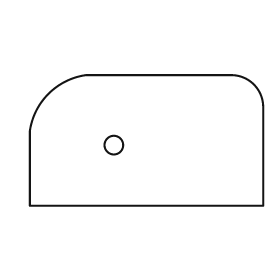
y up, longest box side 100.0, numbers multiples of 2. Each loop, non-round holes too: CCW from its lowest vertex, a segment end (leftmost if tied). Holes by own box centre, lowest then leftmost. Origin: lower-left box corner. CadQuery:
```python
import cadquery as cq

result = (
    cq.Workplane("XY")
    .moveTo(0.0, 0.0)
    .lineTo(100.0, 0.0)
    .lineTo(100.0, 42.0)
    .threePointArc((96.0, 52.0), (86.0, 56.0))
    .lineTo(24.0, 56.0)
    .threePointArc((8.0, 48.0), (0.0, 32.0))
    .close()
    .moveTo(36.0, 26.0)
    .circle(4.0)
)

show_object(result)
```